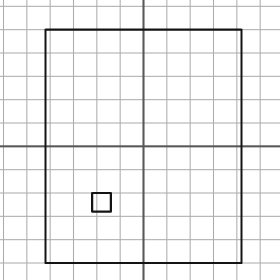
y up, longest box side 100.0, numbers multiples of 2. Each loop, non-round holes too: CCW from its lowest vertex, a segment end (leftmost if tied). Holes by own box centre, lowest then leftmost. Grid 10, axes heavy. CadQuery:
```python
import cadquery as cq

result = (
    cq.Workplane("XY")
    .moveTo(-42.0, -50.0)
    .lineTo(42.0, -50.0)
    .lineTo(42.0, 50.0)
    .lineTo(-42.0, 50.0)
    .close()
    .moveTo(-22.0, -28.0)
    .lineTo(-14.0, -28.0)
    .lineTo(-14.0, -20.0)
    .lineTo(-22.0, -20.0)
    .close()
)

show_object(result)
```